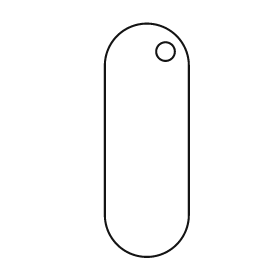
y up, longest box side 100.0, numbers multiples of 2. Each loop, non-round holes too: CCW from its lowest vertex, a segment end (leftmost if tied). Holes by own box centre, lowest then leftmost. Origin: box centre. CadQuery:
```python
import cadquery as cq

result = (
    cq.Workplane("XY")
    .moveTo(-18.0, -32.0)
    .threePointArc((0.0, -50.0), (18.0, -32.0))
    .lineTo(18.0, 32.0)
    .threePointArc((0.0, 50.0), (-18.0, 32.0))
    .close()
    .moveTo(8.0, 38.0)
    .circle(4.0)
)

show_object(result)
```